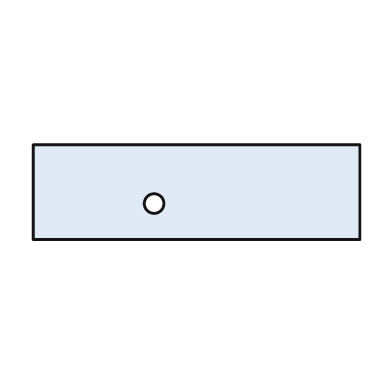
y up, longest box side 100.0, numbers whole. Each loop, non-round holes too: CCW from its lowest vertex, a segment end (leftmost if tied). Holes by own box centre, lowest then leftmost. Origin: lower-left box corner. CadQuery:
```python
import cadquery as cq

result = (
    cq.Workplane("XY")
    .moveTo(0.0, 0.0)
    .lineTo(100.0, 0.0)
    .lineTo(100.0, 29.0)
    .lineTo(0.0, 29.0)
    .close()
    .moveTo(37.0, 11.0)
    .circle(3.0)
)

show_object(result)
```